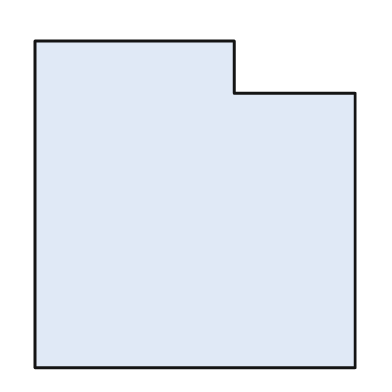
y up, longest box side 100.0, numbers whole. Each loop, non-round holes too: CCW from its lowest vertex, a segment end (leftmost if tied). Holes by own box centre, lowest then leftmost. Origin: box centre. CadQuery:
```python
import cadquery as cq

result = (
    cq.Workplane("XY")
    .moveTo(-49.0, -50.0)
    .lineTo(49.0, -50.0)
    .lineTo(49.0, 34.0)
    .lineTo(12.0, 34.0)
    .lineTo(12.0, 50.0)
    .lineTo(-49.0, 50.0)
    .close()
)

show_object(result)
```